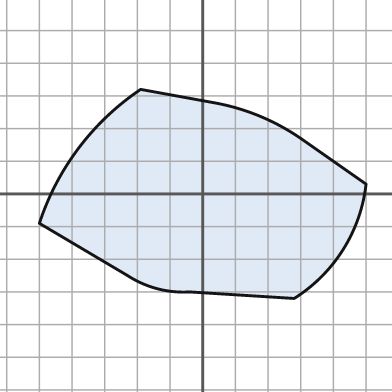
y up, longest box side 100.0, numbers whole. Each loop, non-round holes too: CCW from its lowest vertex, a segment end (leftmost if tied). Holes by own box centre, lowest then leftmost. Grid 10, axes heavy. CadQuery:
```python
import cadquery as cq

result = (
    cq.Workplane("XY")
    .moveTo(28.0, -32.0)
    .threePointArc((43.0, -17.0), (50.0, 3.0))
    .lineTo(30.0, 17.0)
    .threePointArc((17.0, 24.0), (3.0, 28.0))
    .lineTo(-19.0, 32.0)
    .threePointArc((-38.0, 14.0), (-50.0, -9.0))
    .lineTo(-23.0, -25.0)
    .threePointArc((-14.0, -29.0), (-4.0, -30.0))
    .close()
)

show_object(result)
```